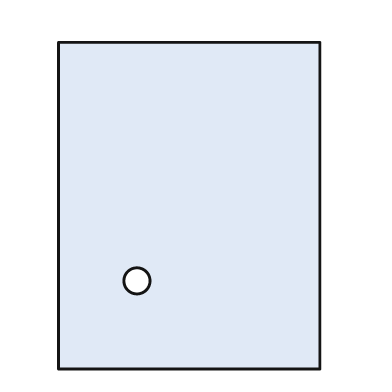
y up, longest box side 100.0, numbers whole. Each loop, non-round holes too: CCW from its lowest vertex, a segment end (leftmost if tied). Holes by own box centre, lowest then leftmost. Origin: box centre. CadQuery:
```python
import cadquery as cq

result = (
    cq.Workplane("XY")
    .moveTo(-40.0, -50.0)
    .lineTo(40.0, -50.0)
    .lineTo(40.0, 50.0)
    .lineTo(-40.0, 50.0)
    .close()
    .moveTo(-16.0, -23.0)
    .circle(4.0)
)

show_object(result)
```